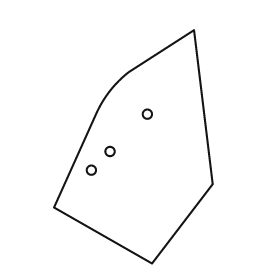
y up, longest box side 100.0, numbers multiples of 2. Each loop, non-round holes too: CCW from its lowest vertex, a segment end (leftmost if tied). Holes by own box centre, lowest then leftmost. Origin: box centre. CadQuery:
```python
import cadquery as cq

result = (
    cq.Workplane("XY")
    .moveTo(8.0, -50.0)
    .lineTo(34.0, -16.0)
    .lineTo(26.0, 50.0)
    .lineTo(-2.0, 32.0)
    .threePointArc((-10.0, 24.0), (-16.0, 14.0))
    .lineTo(-34.0, -26.0)
    .close()
    .moveTo(-18.0, -10.0)
    .circle(2.0)
    .moveTo(-10.0, -2.0)
    .circle(2.0)
    .moveTo(6.0, 14.0)
    .circle(2.0)
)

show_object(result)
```